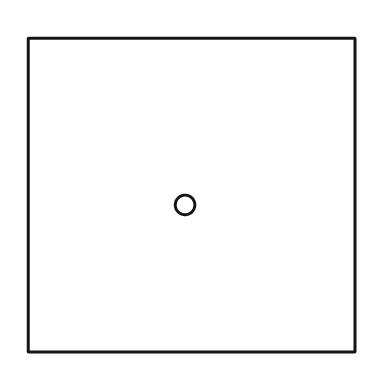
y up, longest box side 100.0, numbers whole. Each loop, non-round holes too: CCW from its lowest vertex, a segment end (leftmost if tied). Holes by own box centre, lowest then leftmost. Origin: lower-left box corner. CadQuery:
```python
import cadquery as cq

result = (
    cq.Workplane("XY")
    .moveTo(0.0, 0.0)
    .lineTo(100.0, 0.0)
    .lineTo(100.0, 96.0)
    .lineTo(0.0, 96.0)
    .close()
    .moveTo(48.0, 45.0)
    .circle(3.0)
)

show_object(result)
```